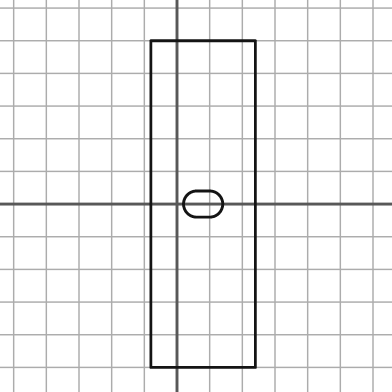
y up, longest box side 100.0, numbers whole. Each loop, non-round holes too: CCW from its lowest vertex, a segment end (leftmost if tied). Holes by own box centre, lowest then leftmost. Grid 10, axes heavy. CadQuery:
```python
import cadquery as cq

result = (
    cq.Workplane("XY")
    .moveTo(-8.0, -50.0)
    .lineTo(24.0, -50.0)
    .lineTo(24.0, 50.0)
    .lineTo(-8.0, 50.0)
    .close()
    .moveTo(6.0, -4.0)
    .lineTo(10.0, -4.0)
    .threePointArc((14.0, 0.0), (10.0, 4.0))
    .lineTo(6.0, 4.0)
    .threePointArc((2.0, 0.0), (6.0, -4.0))
    .close()
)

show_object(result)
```